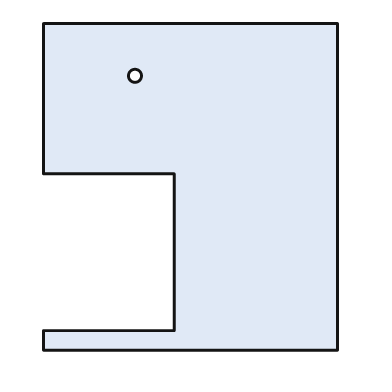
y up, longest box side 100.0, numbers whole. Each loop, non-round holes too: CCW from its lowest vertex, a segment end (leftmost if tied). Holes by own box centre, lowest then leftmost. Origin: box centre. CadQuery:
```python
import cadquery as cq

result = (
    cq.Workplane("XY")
    .moveTo(-45.0, -50.0)
    .lineTo(45.0, -50.0)
    .lineTo(45.0, 50.0)
    .lineTo(-45.0, 50.0)
    .lineTo(-45.0, 4.0)
    .lineTo(-5.0, 4.0)
    .lineTo(-5.0, -44.0)
    .lineTo(-45.0, -44.0)
    .close()
    .moveTo(-17.0, 34.0)
    .circle(2.0)
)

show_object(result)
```